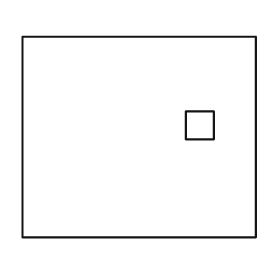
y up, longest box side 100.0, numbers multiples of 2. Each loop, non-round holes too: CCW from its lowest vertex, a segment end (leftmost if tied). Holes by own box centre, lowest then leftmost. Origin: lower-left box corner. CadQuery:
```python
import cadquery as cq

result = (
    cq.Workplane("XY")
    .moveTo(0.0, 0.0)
    .lineTo(100.0, 0.0)
    .lineTo(100.0, 86.0)
    .lineTo(0.0, 86.0)
    .close()
    .moveTo(70.0, 42.0)
    .lineTo(82.0, 42.0)
    .lineTo(82.0, 54.0)
    .lineTo(70.0, 54.0)
    .close()
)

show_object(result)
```